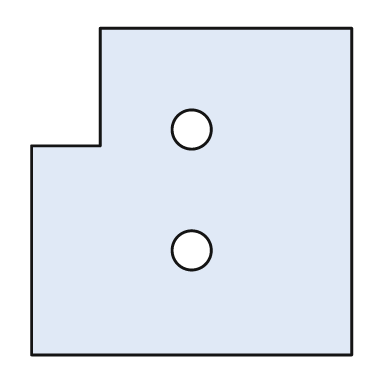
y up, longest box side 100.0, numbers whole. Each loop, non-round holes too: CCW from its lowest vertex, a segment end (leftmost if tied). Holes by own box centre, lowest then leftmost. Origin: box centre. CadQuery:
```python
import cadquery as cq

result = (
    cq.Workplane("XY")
    .moveTo(-49.0, -50.0)
    .lineTo(49.0, -50.0)
    .lineTo(49.0, 50.0)
    .lineTo(-28.0, 50.0)
    .lineTo(-28.0, 14.0)
    .lineTo(-49.0, 14.0)
    .close()
    .moveTo(0.0, -18.0)
    .circle(6.0)
    .moveTo(0.0, 19.0)
    .circle(6.0)
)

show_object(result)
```